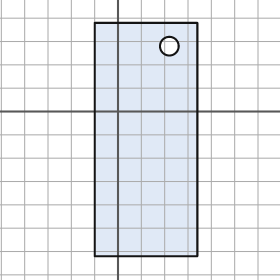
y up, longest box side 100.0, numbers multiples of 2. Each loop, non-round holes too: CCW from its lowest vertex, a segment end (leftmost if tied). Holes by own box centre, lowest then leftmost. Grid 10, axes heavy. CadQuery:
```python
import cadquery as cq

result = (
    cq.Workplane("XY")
    .moveTo(-10.0, -62.0)
    .lineTo(34.0, -62.0)
    .lineTo(34.0, 38.0)
    .lineTo(-10.0, 38.0)
    .close()
    .moveTo(22.0, 28.0)
    .circle(4.0)
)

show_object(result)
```